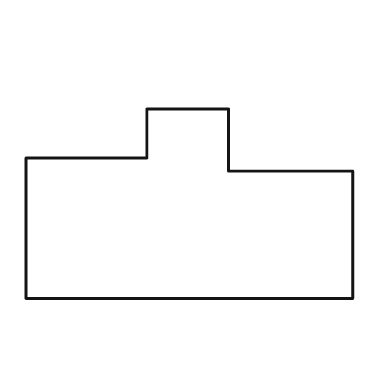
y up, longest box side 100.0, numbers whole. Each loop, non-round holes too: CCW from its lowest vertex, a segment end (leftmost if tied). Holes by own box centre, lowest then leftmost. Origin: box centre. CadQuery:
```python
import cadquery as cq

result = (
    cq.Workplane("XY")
    .moveTo(-50.0, -29.0)
    .lineTo(50.0, -29.0)
    .lineTo(50.0, 10.0)
    .lineTo(12.0, 10.0)
    .lineTo(12.0, 29.0)
    .lineTo(-13.0, 29.0)
    .lineTo(-13.0, 14.0)
    .lineTo(-50.0, 14.0)
    .close()
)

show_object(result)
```